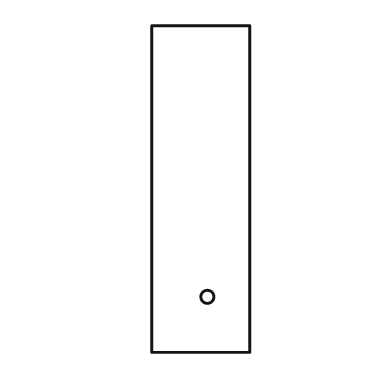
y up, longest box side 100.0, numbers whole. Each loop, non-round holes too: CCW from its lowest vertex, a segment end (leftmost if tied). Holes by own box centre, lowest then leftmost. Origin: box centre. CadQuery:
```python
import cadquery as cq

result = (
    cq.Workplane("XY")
    .moveTo(-15.0, -50.0)
    .lineTo(15.0, -50.0)
    .lineTo(15.0, 50.0)
    .lineTo(-15.0, 50.0)
    .close()
    .moveTo(2.0, -33.0)
    .circle(2.0)
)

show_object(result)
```